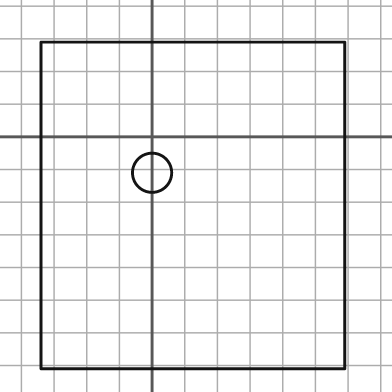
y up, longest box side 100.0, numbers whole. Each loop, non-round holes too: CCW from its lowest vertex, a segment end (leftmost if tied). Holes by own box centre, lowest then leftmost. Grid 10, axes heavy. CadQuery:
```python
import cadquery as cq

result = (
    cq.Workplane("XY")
    .moveTo(-34.0, -71.0)
    .lineTo(59.0, -71.0)
    .lineTo(59.0, 29.0)
    .lineTo(-34.0, 29.0)
    .close()
    .moveTo(0.0, -11.0)
    .circle(6.0)
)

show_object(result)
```